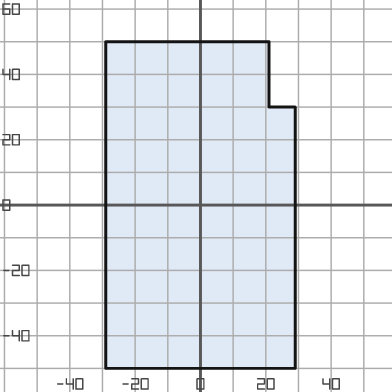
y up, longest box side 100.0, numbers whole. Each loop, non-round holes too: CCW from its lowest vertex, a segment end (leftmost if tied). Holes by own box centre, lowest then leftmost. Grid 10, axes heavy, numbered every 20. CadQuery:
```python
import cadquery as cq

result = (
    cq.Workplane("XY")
    .moveTo(-29.0, -50.0)
    .lineTo(29.0, -50.0)
    .lineTo(29.0, 30.0)
    .lineTo(21.0, 30.0)
    .lineTo(21.0, 50.0)
    .lineTo(-29.0, 50.0)
    .close()
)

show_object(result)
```